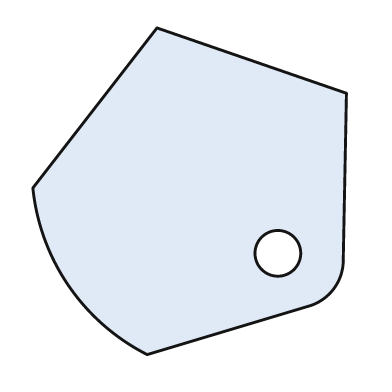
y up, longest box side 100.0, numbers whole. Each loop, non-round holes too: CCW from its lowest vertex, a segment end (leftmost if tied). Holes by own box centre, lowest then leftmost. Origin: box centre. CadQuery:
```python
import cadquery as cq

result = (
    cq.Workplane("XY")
    .moveTo(-13.0, -50.0)
    .lineTo(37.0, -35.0)
    .threePointArc((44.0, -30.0), (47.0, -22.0))
    .lineTo(48.0, 30.0)
    .lineTo(-10.0, 50.0)
    .lineTo(-48.0, 1.0)
    .threePointArc((-37.0, -29.0), (-13.0, -50.0))
    .close()
    .moveTo(27.0, -19.0)
    .circle(7.0)
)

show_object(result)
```